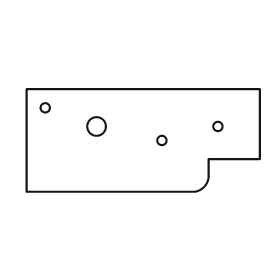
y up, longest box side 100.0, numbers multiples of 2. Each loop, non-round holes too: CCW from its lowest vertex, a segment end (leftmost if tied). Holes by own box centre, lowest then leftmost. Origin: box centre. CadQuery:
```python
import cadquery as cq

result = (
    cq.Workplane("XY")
    .moveTo(-50.0, -22.0)
    .lineTo(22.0, -22.0)
    .threePointArc((26.0, -20.0), (28.0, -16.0))
    .lineTo(28.0, -8.0)
    .lineTo(50.0, -8.0)
    .lineTo(50.0, 22.0)
    .lineTo(-50.0, 22.0)
    .close()
    .moveTo(8.0, 0.0)
    .circle(2.0)
    .moveTo(-20.0, 6.0)
    .circle(4.0)
    .moveTo(32.0, 6.0)
    .circle(2.0)
    .moveTo(-42.0, 14.0)
    .circle(2.0)
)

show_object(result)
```